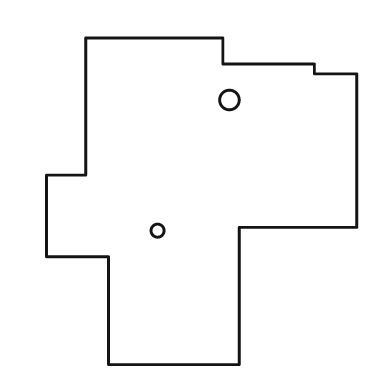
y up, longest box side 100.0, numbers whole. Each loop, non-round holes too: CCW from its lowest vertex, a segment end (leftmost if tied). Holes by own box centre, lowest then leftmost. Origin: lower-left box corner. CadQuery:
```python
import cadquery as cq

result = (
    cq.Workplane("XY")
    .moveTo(19.0, 0.0)
    .lineTo(59.0, 0.0)
    .lineTo(59.0, 42.0)
    .lineTo(95.0, 42.0)
    .lineTo(95.0, 89.0)
    .lineTo(82.0, 89.0)
    .lineTo(82.0, 92.0)
    .lineTo(54.0, 92.0)
    .lineTo(54.0, 100.0)
    .lineTo(12.0, 100.0)
    .lineTo(12.0, 58.0)
    .lineTo(0.0, 58.0)
    .lineTo(0.0, 33.0)
    .lineTo(19.0, 33.0)
    .close()
    .moveTo(34.0, 41.0)
    .circle(2.0)
    .moveTo(56.0, 81.0)
    .circle(3.0)
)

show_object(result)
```